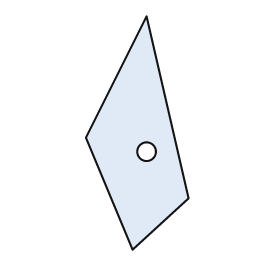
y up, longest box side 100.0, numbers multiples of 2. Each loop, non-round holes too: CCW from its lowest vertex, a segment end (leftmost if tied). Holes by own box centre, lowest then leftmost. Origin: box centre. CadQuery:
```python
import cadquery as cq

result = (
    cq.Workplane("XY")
    .moveTo(-2.0, -50.0)
    .lineTo(22.0, -28.0)
    .lineTo(4.0, 50.0)
    .lineTo(-22.0, -2.0)
    .close()
    .moveTo(4.0, -8.0)
    .circle(4.0)
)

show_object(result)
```